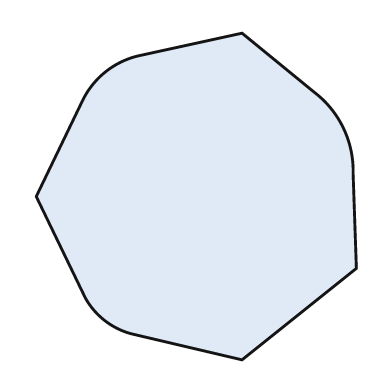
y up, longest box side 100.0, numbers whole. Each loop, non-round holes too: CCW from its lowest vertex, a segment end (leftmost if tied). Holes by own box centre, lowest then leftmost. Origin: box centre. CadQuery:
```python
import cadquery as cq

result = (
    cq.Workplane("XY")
    .moveTo(14.0, -50.0)
    .lineTo(49.0, -22.0)
    .lineTo(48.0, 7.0)
    .threePointArc((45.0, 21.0), (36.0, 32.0))
    .lineTo(14.0, 50.0)
    .lineTo(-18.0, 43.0)
    .threePointArc((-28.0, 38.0), (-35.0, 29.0))
    .lineTo(-49.0, 0.0)
    .lineTo(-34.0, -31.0)
    .threePointArc((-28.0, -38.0), (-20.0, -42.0))
    .close()
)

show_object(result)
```